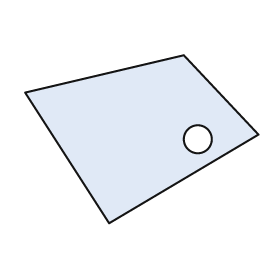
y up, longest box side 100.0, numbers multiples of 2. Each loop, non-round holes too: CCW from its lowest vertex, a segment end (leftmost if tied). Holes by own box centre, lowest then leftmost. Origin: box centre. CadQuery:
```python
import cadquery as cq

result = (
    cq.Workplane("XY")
    .moveTo(-14.0, -36.0)
    .lineTo(50.0, 2.0)
    .lineTo(18.0, 36.0)
    .lineTo(-50.0, 20.0)
    .close()
    .moveTo(24.0, 0.0)
    .circle(6.0)
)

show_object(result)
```